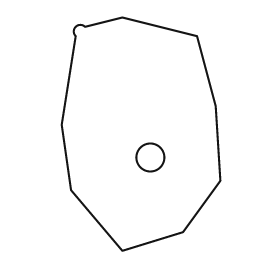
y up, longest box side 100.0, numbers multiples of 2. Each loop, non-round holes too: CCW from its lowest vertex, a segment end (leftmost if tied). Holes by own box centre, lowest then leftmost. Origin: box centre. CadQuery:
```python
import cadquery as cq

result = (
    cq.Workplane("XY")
    .moveTo(-8.0, -50.0)
    .lineTo(18.0, -42.0)
    .lineTo(34.0, -20.0)
    .lineTo(32.0, 12.0)
    .lineTo(24.0, 42.0)
    .lineTo(-8.0, 50.0)
    .lineTo(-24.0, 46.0)
    .threePointArc((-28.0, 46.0), (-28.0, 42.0))
    .lineTo(-34.0, 4.0)
    .lineTo(-30.0, -24.0)
    .close()
    .moveTo(4.0, -10.0)
    .circle(6.0)
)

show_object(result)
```